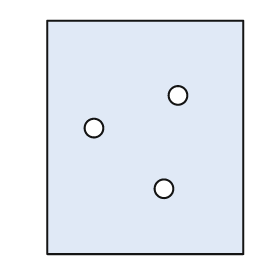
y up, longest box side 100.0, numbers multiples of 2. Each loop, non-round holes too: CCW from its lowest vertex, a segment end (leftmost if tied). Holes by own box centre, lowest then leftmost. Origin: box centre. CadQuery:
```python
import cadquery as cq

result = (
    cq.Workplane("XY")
    .moveTo(-42.0, -50.0)
    .lineTo(42.0, -50.0)
    .lineTo(42.0, 50.0)
    .lineTo(-42.0, 50.0)
    .close()
    .moveTo(8.0, -22.0)
    .circle(4.0)
    .moveTo(-22.0, 4.0)
    .circle(4.0)
    .moveTo(14.0, 18.0)
    .circle(4.0)
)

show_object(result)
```